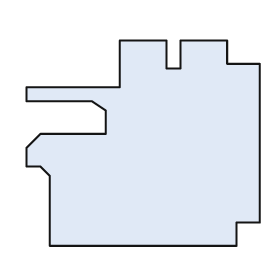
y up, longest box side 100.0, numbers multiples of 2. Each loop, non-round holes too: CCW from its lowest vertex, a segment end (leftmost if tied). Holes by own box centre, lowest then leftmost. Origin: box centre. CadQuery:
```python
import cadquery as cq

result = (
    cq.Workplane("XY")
    .moveTo(-40.0, -44.0)
    .lineTo(40.0, -44.0)
    .lineTo(40.0, -34.0)
    .lineTo(50.0, -34.0)
    .lineTo(50.0, 34.0)
    .lineTo(36.0, 34.0)
    .lineTo(36.0, 44.0)
    .lineTo(16.0, 44.0)
    .lineTo(16.0, 32.0)
    .lineTo(10.0, 32.0)
    .lineTo(10.0, 44.0)
    .lineTo(-10.0, 44.0)
    .lineTo(-10.0, 24.0)
    .lineTo(-50.0, 24.0)
    .lineTo(-50.0, 18.0)
    .lineTo(-22.0, 18.0)
    .lineTo(-16.0, 14.0)
    .lineTo(-16.0, 4.0)
    .lineTo(-44.0, 4.0)
    .lineTo(-50.0, -2.0)
    .lineTo(-50.0, -10.0)
    .lineTo(-44.0, -10.0)
    .lineTo(-40.0, -14.0)
    .close()
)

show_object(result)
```